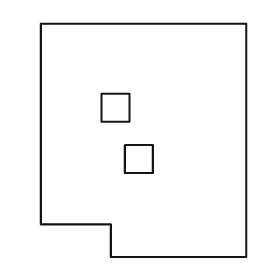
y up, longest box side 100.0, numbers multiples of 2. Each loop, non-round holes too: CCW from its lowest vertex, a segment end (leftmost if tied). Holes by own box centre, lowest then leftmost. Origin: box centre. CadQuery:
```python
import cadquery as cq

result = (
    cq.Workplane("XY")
    .moveTo(-14.0, -50.0)
    .lineTo(44.0, -50.0)
    .lineTo(44.0, 50.0)
    .lineTo(-44.0, 50.0)
    .lineTo(-44.0, -36.0)
    .lineTo(-14.0, -36.0)
    .close()
    .moveTo(-8.0, -14.0)
    .lineTo(4.0, -14.0)
    .lineTo(4.0, -2.0)
    .lineTo(-8.0, -2.0)
    .close()
    .moveTo(-18.0, 8.0)
    .lineTo(-6.0, 8.0)
    .lineTo(-6.0, 20.0)
    .lineTo(-18.0, 20.0)
    .close()
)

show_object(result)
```